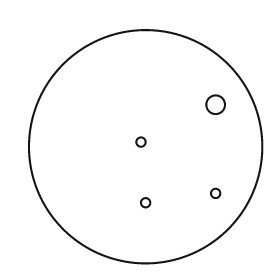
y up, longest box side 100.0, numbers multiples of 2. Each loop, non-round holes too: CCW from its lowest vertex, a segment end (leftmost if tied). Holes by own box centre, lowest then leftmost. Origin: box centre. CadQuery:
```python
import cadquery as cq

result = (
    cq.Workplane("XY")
    .moveTo(0.0, 0.0)
    .circle(50.0)
    .moveTo(0.0, -24.0)
    .circle(2.0)
    .moveTo(30.0, -20.0)
    .circle(2.0)
    .moveTo(-2.0, 2.0)
    .circle(2.0)
    .moveTo(30.0, 18.0)
    .circle(4.0)
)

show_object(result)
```